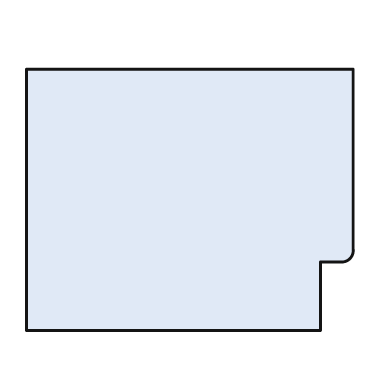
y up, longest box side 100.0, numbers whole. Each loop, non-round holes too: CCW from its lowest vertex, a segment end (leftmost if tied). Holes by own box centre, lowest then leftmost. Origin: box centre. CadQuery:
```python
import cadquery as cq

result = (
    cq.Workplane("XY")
    .moveTo(-50.0, -40.0)
    .lineTo(40.0, -40.0)
    .lineTo(40.0, -19.0)
    .lineTo(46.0, -19.0)
    .threePointArc((49.0, -18.0), (50.0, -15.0))
    .lineTo(50.0, 40.0)
    .lineTo(-50.0, 40.0)
    .close()
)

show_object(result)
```